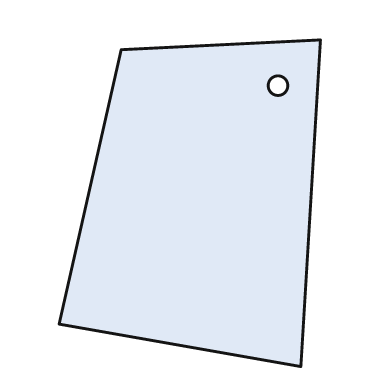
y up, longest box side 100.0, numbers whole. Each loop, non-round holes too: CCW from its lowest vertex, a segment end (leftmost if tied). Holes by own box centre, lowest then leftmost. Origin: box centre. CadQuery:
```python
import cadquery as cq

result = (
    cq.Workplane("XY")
    .moveTo(34.0, -50.0)
    .lineTo(40.0, 50.0)
    .lineTo(-21.0, 47.0)
    .lineTo(-40.0, -37.0)
    .close()
    .moveTo(27.0, 36.0)
    .circle(3.0)
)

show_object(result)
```